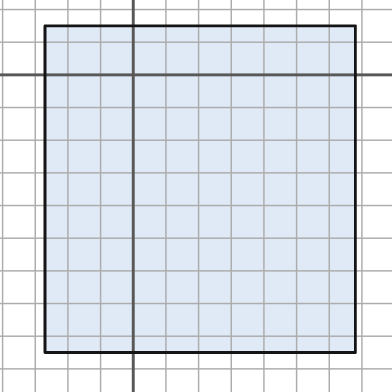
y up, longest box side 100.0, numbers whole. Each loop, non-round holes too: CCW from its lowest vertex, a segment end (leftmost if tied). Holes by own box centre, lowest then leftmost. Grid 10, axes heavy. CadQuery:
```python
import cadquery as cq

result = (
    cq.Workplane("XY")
    .moveTo(-27.0, -85.0)
    .lineTo(68.0, -85.0)
    .lineTo(68.0, 15.0)
    .lineTo(-27.0, 15.0)
    .close()
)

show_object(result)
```